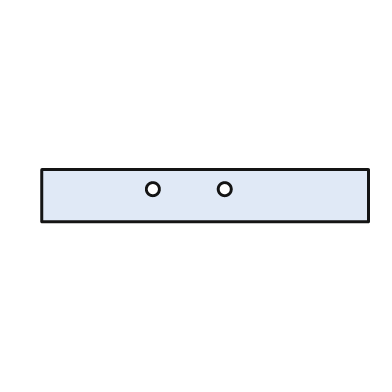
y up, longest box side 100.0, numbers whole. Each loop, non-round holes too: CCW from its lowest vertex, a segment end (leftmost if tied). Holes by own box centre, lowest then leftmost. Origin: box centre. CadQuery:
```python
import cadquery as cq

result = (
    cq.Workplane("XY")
    .moveTo(-50.0, -8.0)
    .lineTo(50.0, -8.0)
    .lineTo(50.0, 8.0)
    .lineTo(-50.0, 8.0)
    .close()
    .moveTo(-16.0, 2.0)
    .circle(2.0)
    .moveTo(6.0, 2.0)
    .circle(2.0)
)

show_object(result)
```